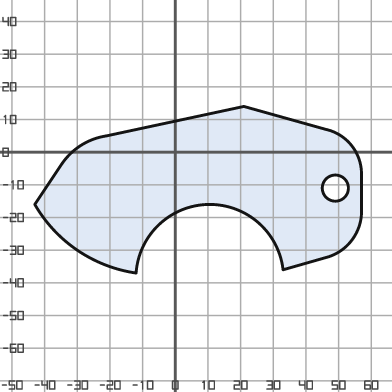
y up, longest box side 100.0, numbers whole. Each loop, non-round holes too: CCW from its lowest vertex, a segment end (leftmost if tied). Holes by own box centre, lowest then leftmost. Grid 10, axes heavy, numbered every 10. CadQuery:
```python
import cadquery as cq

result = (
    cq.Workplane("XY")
    .moveTo(-12.0, -37.0)
    .threePointArc((10.0, -16.0), (33.0, -36.0))
    .lineTo(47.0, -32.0)
    .threePointArc((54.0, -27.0), (57.0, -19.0))
    .lineTo(57.0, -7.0)
    .threePointArc((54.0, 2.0), (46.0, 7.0))
    .lineTo(21.0, 14.0)
    .lineTo(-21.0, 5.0)
    .threePointArc((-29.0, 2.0), (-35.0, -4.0))
    .lineTo(-43.0, -16.0)
    .threePointArc((-30.0, -30.0), (-12.0, -37.0))
    .close()
    .moveTo(49.0, -11.0)
    .circle(4.0)
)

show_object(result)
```